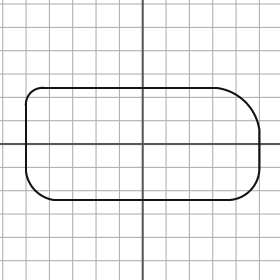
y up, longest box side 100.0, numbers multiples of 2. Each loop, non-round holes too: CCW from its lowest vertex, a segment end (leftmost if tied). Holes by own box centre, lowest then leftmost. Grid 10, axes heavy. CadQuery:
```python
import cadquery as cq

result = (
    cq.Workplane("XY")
    .moveTo(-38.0, -24.0)
    .lineTo(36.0, -24.0)
    .threePointArc((46.0, -20.0), (50.0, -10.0))
    .lineTo(50.0, 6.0)
    .threePointArc((44.0, 18.0), (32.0, 24.0))
    .lineTo(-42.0, 24.0)
    .threePointArc((-48.0, 22.0), (-50.0, 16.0))
    .lineTo(-50.0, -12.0)
    .threePointArc((-46.0, -20.0), (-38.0, -24.0))
    .close()
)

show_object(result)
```